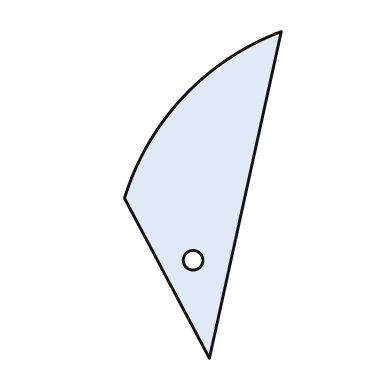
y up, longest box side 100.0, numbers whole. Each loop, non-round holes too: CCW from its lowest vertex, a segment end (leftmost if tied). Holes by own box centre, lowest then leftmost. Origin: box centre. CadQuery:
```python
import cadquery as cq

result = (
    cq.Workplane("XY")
    .moveTo(2.0, -50.0)
    .lineTo(24.0, 50.0)
    .threePointArc((-6.0, 30.0), (-24.0, -1.0))
    .close()
    .moveTo(-3.0, -20.0)
    .circle(3.0)
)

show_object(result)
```